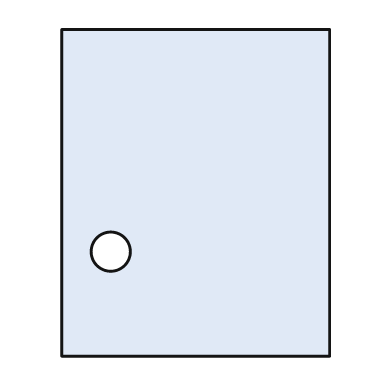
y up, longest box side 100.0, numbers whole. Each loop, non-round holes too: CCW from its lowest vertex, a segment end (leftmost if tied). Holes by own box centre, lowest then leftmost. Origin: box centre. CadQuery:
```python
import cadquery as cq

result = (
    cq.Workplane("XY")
    .moveTo(-41.0, -50.0)
    .lineTo(41.0, -50.0)
    .lineTo(41.0, 50.0)
    .lineTo(-41.0, 50.0)
    .close()
    .moveTo(-26.0, -18.0)
    .circle(6.0)
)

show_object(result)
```